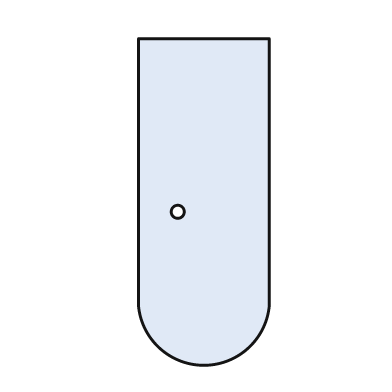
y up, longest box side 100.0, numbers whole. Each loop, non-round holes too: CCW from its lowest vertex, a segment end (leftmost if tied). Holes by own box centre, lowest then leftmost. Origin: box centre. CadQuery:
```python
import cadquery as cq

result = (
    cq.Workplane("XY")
    .moveTo(-20.0, -32.0)
    .threePointArc((0.0, -50.0), (20.0, -32.0))
    .lineTo(20.0, 50.0)
    .lineTo(-20.0, 50.0)
    .close()
    .moveTo(-8.0, -3.0)
    .circle(2.0)
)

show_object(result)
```